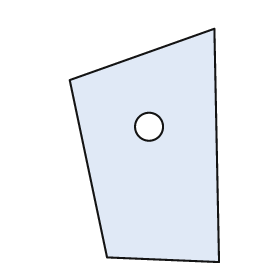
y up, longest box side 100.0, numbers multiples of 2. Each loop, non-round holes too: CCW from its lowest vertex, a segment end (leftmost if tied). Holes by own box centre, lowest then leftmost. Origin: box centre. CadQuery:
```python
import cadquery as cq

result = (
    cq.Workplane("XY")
    .moveTo(32.0, -50.0)
    .lineTo(30.0, 50.0)
    .lineTo(-32.0, 28.0)
    .lineTo(-16.0, -48.0)
    .close()
    .moveTo(2.0, 8.0)
    .circle(6.0)
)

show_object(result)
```